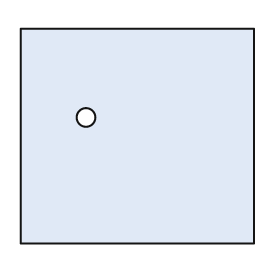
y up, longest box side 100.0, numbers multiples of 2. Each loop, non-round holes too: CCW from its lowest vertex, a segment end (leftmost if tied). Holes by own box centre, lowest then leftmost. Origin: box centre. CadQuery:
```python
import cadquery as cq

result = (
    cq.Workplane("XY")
    .moveTo(-50.0, -46.0)
    .lineTo(50.0, -46.0)
    .lineTo(50.0, 46.0)
    .lineTo(-50.0, 46.0)
    .close()
    .moveTo(-22.0, 8.0)
    .circle(4.0)
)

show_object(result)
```